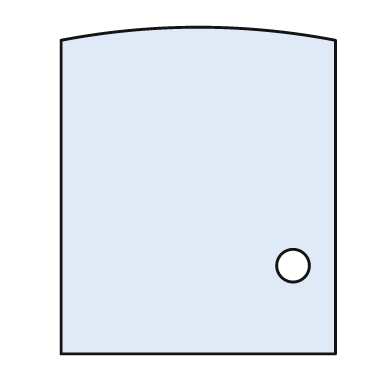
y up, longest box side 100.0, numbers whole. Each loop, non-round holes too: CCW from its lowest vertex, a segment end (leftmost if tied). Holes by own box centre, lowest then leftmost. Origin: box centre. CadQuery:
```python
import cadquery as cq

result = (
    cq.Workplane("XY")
    .moveTo(-42.0, -50.0)
    .lineTo(42.0, -50.0)
    .lineTo(42.0, 46.0)
    .threePointArc((0.0, 50.0), (-42.0, 46.0))
    .close()
    .moveTo(29.0, -23.0)
    .circle(5.0)
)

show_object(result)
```